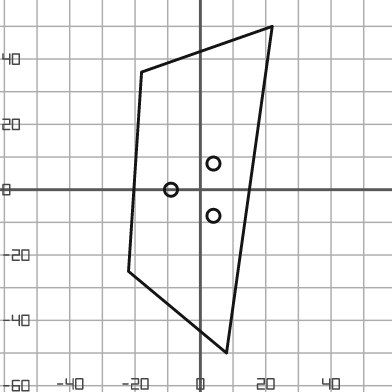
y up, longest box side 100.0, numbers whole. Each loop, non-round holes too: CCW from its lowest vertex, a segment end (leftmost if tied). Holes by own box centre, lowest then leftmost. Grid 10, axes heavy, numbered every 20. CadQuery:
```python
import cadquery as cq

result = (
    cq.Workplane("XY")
    .moveTo(8.0, -50.0)
    .lineTo(22.0, 50.0)
    .lineTo(-18.0, 36.0)
    .lineTo(-22.0, -25.0)
    .close()
    .moveTo(4.0, -8.0)
    .circle(2.0)
    .moveTo(-9.0, 0.0)
    .circle(2.0)
    .moveTo(4.0, 8.0)
    .circle(2.0)
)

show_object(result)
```